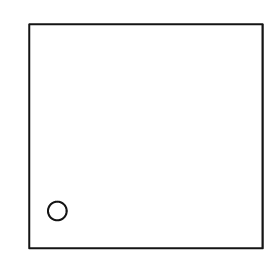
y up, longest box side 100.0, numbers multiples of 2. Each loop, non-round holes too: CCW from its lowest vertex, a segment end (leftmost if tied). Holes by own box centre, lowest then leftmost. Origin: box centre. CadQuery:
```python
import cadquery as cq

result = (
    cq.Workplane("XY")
    .moveTo(-50.0, -48.0)
    .lineTo(50.0, -48.0)
    .lineTo(50.0, 48.0)
    .lineTo(-50.0, 48.0)
    .close()
    .moveTo(-38.0, -32.0)
    .circle(4.0)
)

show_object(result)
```